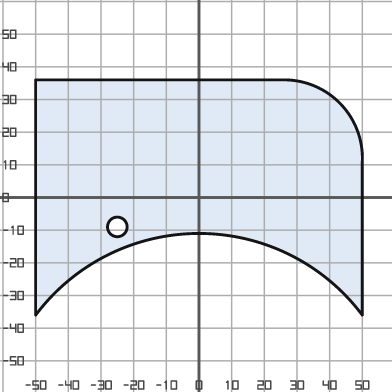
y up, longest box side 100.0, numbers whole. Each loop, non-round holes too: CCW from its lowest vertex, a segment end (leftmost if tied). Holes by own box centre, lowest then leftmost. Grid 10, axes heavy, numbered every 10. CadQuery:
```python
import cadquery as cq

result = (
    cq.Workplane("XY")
    .moveTo(-50.0, -36.0)
    .threePointArc((0.0, -11.0), (50.0, -36.0))
    .lineTo(50.0, 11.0)
    .threePointArc((43.0, 29.0), (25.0, 36.0))
    .lineTo(-50.0, 36.0)
    .close()
    .moveTo(-25.0, -9.0)
    .circle(3.0)
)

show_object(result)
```